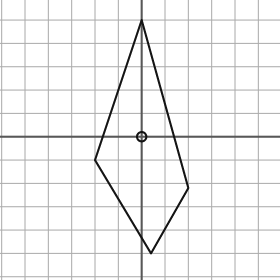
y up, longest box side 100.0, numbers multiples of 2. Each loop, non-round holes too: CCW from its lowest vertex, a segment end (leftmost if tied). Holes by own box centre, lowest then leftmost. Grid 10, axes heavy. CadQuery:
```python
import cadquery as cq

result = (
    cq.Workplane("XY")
    .moveTo(4.0, -50.0)
    .lineTo(20.0, -22.0)
    .lineTo(0.0, 50.0)
    .lineTo(-20.0, -10.0)
    .close()
    .moveTo(0.0, 0.0)
    .circle(2.0)
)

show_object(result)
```